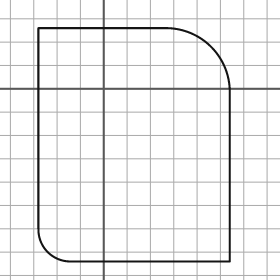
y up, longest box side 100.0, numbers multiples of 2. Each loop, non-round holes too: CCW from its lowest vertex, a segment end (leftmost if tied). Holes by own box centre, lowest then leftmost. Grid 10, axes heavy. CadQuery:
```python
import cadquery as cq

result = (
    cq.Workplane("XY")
    .moveTo(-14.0, -74.0)
    .lineTo(54.0, -74.0)
    .lineTo(54.0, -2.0)
    .threePointArc((46.0, 18.0), (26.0, 26.0))
    .lineTo(-28.0, 26.0)
    .lineTo(-28.0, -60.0)
    .threePointArc((-24.0, -70.0), (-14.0, -74.0))
    .close()
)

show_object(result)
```